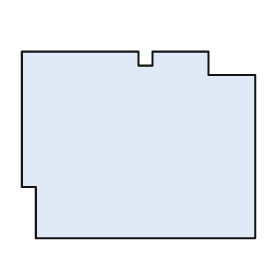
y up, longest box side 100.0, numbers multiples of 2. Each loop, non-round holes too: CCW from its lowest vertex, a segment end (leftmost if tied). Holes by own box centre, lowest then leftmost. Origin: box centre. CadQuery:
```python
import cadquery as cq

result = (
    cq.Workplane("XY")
    .moveTo(-44.0, -40.0)
    .lineTo(50.0, -40.0)
    .lineTo(50.0, 30.0)
    .lineTo(30.0, 30.0)
    .lineTo(30.0, 40.0)
    .lineTo(6.0, 40.0)
    .lineTo(6.0, 34.0)
    .lineTo(0.0, 34.0)
    .lineTo(0.0, 40.0)
    .lineTo(-50.0, 40.0)
    .lineTo(-50.0, -18.0)
    .lineTo(-44.0, -18.0)
    .close()
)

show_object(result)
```